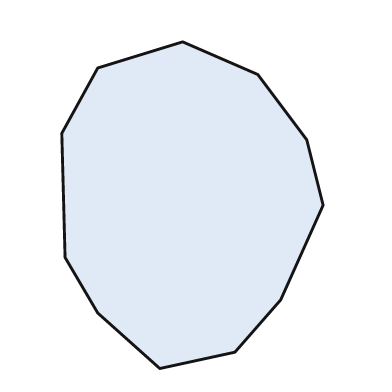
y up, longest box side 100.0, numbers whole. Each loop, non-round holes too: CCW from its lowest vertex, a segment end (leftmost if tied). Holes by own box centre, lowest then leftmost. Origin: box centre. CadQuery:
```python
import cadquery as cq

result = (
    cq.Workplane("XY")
    .moveTo(-10.0, -50.0)
    .lineTo(13.0, -45.0)
    .lineTo(27.0, -29.0)
    .lineTo(40.0, 0.0)
    .lineTo(35.0, 20.0)
    .lineTo(20.0, 40.0)
    .lineTo(-3.0, 50.0)
    .lineTo(-29.0, 42.0)
    .lineTo(-40.0, 22.0)
    .lineTo(-39.0, -16.0)
    .lineTo(-29.0, -33.0)
    .close()
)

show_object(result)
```